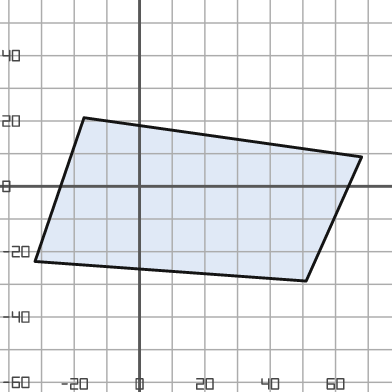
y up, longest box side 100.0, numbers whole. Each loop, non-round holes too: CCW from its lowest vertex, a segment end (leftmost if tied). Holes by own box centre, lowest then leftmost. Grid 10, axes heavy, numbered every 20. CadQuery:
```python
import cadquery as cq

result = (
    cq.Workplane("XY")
    .moveTo(51.0, -29.0)
    .lineTo(68.0, 9.0)
    .lineTo(-17.0, 21.0)
    .lineTo(-32.0, -23.0)
    .close()
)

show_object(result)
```